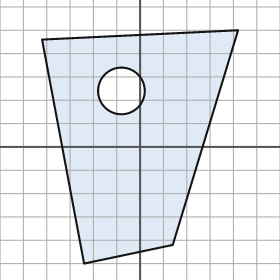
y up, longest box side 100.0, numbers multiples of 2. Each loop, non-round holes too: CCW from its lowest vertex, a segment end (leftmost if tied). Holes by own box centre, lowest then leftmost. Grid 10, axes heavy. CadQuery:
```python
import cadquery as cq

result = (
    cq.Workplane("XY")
    .moveTo(-24.0, -50.0)
    .lineTo(14.0, -42.0)
    .lineTo(42.0, 50.0)
    .lineTo(-42.0, 46.0)
    .close()
    .moveTo(-8.0, 24.0)
    .circle(10.0)
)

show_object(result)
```